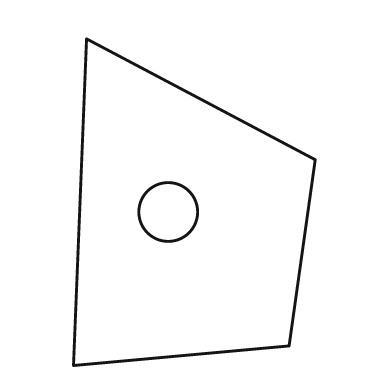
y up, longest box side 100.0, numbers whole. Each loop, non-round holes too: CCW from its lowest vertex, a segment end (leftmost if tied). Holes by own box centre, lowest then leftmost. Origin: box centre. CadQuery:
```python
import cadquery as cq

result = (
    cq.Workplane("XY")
    .moveTo(-37.0, -50.0)
    .lineTo(29.0, -44.0)
    .lineTo(37.0, 13.0)
    .lineTo(-33.0, 50.0)
    .close()
    .moveTo(-8.0, -3.0)
    .circle(9.0)
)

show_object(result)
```